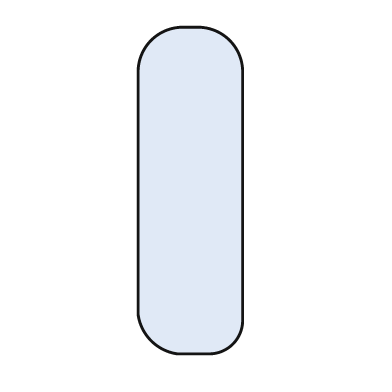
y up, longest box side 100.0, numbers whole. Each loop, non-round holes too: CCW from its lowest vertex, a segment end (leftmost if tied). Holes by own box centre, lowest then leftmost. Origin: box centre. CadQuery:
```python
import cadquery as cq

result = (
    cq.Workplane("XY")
    .moveTo(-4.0, -50.0)
    .lineTo(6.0, -50.0)
    .threePointArc((13.0, -47.0), (16.0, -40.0))
    .lineTo(16.0, 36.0)
    .threePointArc((12.0, 46.0), (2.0, 50.0))
    .lineTo(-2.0, 50.0)
    .threePointArc((-12.0, 46.0), (-16.0, 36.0))
    .lineTo(-16.0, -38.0)
    .threePointArc((-12.0, -46.0), (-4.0, -50.0))
    .close()
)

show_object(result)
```